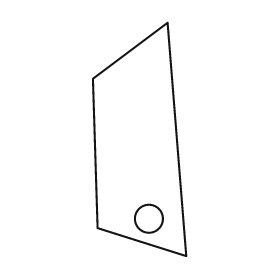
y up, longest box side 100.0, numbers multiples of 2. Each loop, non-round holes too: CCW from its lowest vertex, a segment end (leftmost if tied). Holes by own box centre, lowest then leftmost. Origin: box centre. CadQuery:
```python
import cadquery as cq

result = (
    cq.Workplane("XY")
    .moveTo(20.0, -50.0)
    .lineTo(12.0, 50.0)
    .lineTo(-20.0, 26.0)
    .lineTo(-18.0, -38.0)
    .close()
    .moveTo(4.0, -34.0)
    .circle(6.0)
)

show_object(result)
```